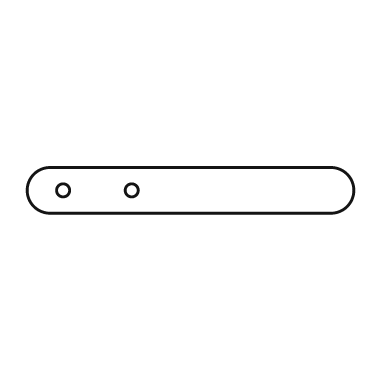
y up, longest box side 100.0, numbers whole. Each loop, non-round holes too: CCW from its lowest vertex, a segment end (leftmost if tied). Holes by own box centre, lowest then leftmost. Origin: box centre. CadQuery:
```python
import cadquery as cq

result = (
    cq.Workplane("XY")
    .moveTo(-43.0, -7.0)
    .lineTo(43.0, -7.0)
    .threePointArc((50.0, 0.0), (43.0, 7.0))
    .lineTo(-43.0, 7.0)
    .threePointArc((-50.0, 0.0), (-43.0, -7.0))
    .close()
    .moveTo(-39.0, 0.0)
    .circle(2.0)
    .moveTo(-18.0, 0.0)
    .circle(2.0)
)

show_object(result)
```